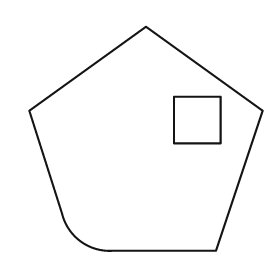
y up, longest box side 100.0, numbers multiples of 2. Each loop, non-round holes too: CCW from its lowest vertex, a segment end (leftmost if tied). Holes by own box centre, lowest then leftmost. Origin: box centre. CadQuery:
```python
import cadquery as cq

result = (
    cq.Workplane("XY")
    .moveTo(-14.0, -48.0)
    .lineTo(30.0, -48.0)
    .lineTo(50.0, 12.0)
    .lineTo(0.0, 48.0)
    .lineTo(-50.0, 12.0)
    .lineTo(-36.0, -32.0)
    .threePointArc((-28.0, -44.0), (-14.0, -48.0))
    .close()
    .moveTo(12.0, -2.0)
    .lineTo(32.0, -2.0)
    .lineTo(32.0, 18.0)
    .lineTo(12.0, 18.0)
    .close()
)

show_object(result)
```